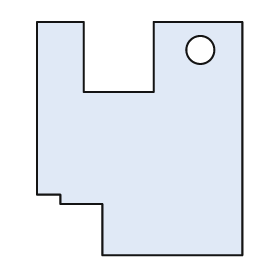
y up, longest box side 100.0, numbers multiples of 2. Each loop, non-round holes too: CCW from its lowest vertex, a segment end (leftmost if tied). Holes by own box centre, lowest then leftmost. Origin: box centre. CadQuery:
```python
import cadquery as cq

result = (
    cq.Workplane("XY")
    .moveTo(-16.0, -50.0)
    .lineTo(44.0, -50.0)
    .lineTo(44.0, 50.0)
    .lineTo(6.0, 50.0)
    .lineTo(6.0, 20.0)
    .lineTo(-24.0, 20.0)
    .lineTo(-24.0, 50.0)
    .lineTo(-44.0, 50.0)
    .lineTo(-44.0, -24.0)
    .lineTo(-34.0, -24.0)
    .lineTo(-34.0, -28.0)
    .lineTo(-16.0, -28.0)
    .close()
    .moveTo(26.0, 38.0)
    .circle(6.0)
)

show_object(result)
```